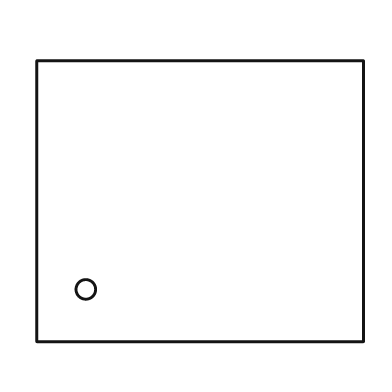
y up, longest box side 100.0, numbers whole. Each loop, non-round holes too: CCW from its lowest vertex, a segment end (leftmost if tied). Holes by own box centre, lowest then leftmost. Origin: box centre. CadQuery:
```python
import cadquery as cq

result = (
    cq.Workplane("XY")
    .moveTo(-50.0, -43.0)
    .lineTo(50.0, -43.0)
    .lineTo(50.0, 43.0)
    .lineTo(-50.0, 43.0)
    .close()
    .moveTo(-35.0, -27.0)
    .circle(3.0)
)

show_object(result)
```